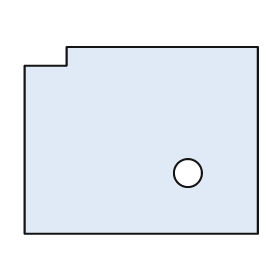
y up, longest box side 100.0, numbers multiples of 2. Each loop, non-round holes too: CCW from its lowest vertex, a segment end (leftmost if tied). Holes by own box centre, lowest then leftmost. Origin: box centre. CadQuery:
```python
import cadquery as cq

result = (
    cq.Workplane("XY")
    .moveTo(-50.0, -40.0)
    .lineTo(50.0, -40.0)
    .lineTo(50.0, 40.0)
    .lineTo(-32.0, 40.0)
    .lineTo(-32.0, 32.0)
    .lineTo(-50.0, 32.0)
    .close()
    .moveTo(20.0, -14.0)
    .circle(6.0)
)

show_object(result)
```